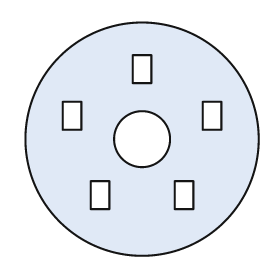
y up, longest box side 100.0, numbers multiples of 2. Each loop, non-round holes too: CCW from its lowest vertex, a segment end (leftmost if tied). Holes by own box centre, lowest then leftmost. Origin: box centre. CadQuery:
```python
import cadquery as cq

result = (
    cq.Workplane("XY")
    .moveTo(0.0, 0.0)
    .circle(50.0)
    .moveTo(-22.0, -30.0)
    .lineTo(-14.0, -30.0)
    .lineTo(-14.0, -18.0)
    .lineTo(-22.0, -18.0)
    .close()
    .moveTo(14.0, -30.0)
    .lineTo(22.0, -30.0)
    .lineTo(22.0, -18.0)
    .lineTo(14.0, -18.0)
    .close()
    .moveTo(0.0, 0.0)
    .circle(12.0)
    .moveTo(-34.0, 4.0)
    .lineTo(-26.0, 4.0)
    .lineTo(-26.0, 16.0)
    .lineTo(-34.0, 16.0)
    .close()
    .moveTo(26.0, 4.0)
    .lineTo(34.0, 4.0)
    .lineTo(34.0, 16.0)
    .lineTo(26.0, 16.0)
    .close()
    .moveTo(-4.0, 24.0)
    .lineTo(4.0, 24.0)
    .lineTo(4.0, 36.0)
    .lineTo(-4.0, 36.0)
    .close()
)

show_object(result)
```